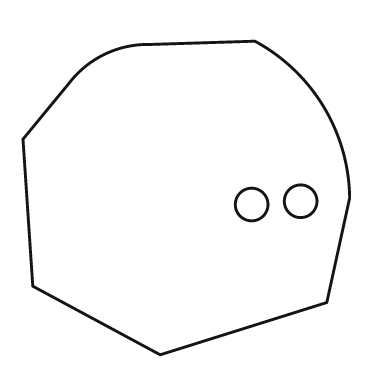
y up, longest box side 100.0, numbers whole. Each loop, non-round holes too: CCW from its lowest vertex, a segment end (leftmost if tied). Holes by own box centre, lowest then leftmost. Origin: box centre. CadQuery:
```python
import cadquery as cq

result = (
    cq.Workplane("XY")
    .moveTo(-8.0, -48.0)
    .lineTo(43.0, -32.0)
    .lineTo(50.0, 0.0)
    .threePointArc((42.0, 28.0), (21.0, 48.0))
    .lineTo(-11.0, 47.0)
    .threePointArc((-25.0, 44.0), (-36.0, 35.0))
    .lineTo(-50.0, 18.0)
    .lineTo(-47.0, -27.0)
    .close()
    .moveTo(20.0, -2.0)
    .circle(5.0)
    .moveTo(35.0, -1.0)
    .circle(5.0)
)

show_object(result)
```